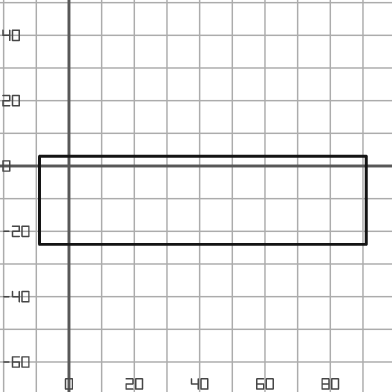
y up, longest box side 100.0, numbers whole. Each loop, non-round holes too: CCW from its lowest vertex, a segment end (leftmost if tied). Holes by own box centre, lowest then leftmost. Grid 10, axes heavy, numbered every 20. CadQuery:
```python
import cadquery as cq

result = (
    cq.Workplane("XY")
    .moveTo(-9.0, -24.0)
    .lineTo(91.0, -24.0)
    .lineTo(91.0, 3.0)
    .lineTo(-9.0, 3.0)
    .close()
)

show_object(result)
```